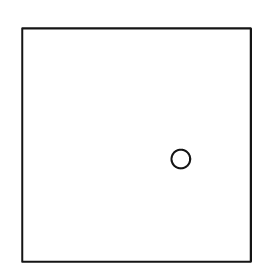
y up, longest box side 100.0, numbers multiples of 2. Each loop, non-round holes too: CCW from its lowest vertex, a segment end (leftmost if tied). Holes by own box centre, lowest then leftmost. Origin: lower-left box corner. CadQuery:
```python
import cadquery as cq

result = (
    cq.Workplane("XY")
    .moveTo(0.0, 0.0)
    .lineTo(98.0, 0.0)
    .lineTo(98.0, 100.0)
    .lineTo(0.0, 100.0)
    .close()
    .moveTo(68.0, 44.0)
    .circle(4.0)
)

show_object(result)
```